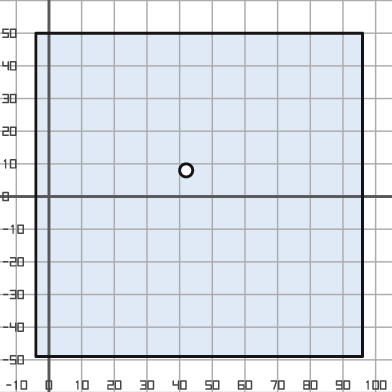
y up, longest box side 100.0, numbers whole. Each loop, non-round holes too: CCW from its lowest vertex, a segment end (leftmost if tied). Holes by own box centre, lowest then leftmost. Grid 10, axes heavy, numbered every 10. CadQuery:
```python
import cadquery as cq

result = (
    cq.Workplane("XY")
    .moveTo(-4.0, -49.0)
    .lineTo(96.0, -49.0)
    .lineTo(96.0, 50.0)
    .lineTo(-4.0, 50.0)
    .close()
    .moveTo(42.0, 8.0)
    .circle(2.0)
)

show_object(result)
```